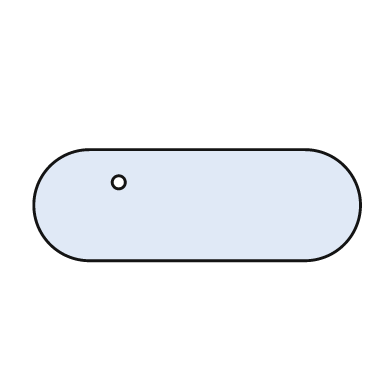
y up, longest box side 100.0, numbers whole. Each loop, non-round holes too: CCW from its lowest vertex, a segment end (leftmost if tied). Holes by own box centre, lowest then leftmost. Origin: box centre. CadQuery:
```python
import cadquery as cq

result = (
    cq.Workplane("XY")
    .moveTo(-33.0, -17.0)
    .lineTo(33.0, -17.0)
    .threePointArc((50.0, 0.0), (33.0, 17.0))
    .lineTo(-33.0, 17.0)
    .threePointArc((-50.0, 0.0), (-33.0, -17.0))
    .close()
    .moveTo(-24.0, 7.0)
    .circle(2.0)
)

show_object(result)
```